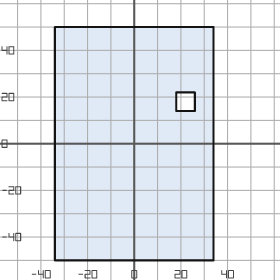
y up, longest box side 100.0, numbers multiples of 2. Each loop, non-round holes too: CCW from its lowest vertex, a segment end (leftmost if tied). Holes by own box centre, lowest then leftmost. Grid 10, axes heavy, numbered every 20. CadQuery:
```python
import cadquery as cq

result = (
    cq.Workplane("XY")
    .moveTo(-34.0, -50.0)
    .lineTo(34.0, -50.0)
    .lineTo(34.0, 50.0)
    .lineTo(-34.0, 50.0)
    .close()
    .moveTo(18.0, 14.0)
    .lineTo(26.0, 14.0)
    .lineTo(26.0, 22.0)
    .lineTo(18.0, 22.0)
    .close()
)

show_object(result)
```